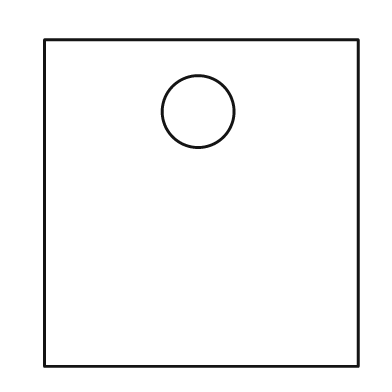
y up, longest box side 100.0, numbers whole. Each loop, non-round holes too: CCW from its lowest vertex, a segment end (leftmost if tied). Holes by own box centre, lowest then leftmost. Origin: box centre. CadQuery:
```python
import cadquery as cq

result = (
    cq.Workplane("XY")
    .moveTo(-48.0, -50.0)
    .lineTo(48.0, -50.0)
    .lineTo(48.0, 50.0)
    .lineTo(-48.0, 50.0)
    .close()
    .moveTo(-1.0, 28.0)
    .circle(11.0)
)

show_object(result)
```